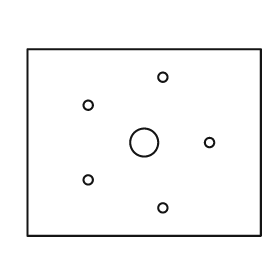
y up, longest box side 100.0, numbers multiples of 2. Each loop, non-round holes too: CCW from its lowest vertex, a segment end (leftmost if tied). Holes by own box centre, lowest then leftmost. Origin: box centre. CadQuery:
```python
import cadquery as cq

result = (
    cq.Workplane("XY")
    .moveTo(-50.0, -40.0)
    .lineTo(50.0, -40.0)
    .lineTo(50.0, 40.0)
    .lineTo(-50.0, 40.0)
    .close()
    .moveTo(8.0, -28.0)
    .circle(2.0)
    .moveTo(-24.0, -16.0)
    .circle(2.0)
    .moveTo(0.0, 0.0)
    .circle(6.0)
    .moveTo(28.0, 0.0)
    .circle(2.0)
    .moveTo(-24.0, 16.0)
    .circle(2.0)
    .moveTo(8.0, 28.0)
    .circle(2.0)
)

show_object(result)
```